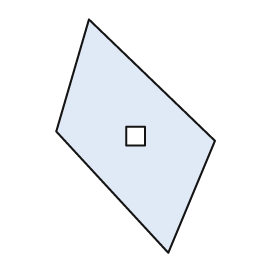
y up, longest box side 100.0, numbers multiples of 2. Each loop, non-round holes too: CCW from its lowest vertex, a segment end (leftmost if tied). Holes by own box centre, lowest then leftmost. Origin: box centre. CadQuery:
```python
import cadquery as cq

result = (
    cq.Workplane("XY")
    .moveTo(14.0, -50.0)
    .lineTo(34.0, -2.0)
    .lineTo(-20.0, 50.0)
    .lineTo(-34.0, 2.0)
    .close()
    .moveTo(-4.0, -4.0)
    .lineTo(4.0, -4.0)
    .lineTo(4.0, 4.0)
    .lineTo(-4.0, 4.0)
    .close()
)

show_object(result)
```